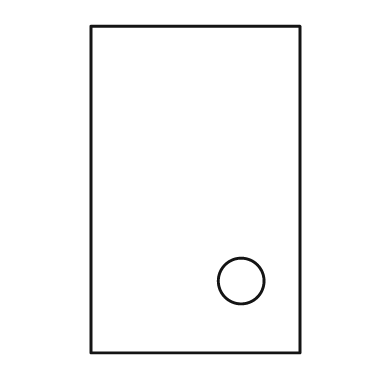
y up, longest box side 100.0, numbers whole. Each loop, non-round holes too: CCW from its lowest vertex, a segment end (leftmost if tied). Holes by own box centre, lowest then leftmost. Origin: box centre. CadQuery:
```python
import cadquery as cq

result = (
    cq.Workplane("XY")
    .moveTo(-32.0, -50.0)
    .lineTo(32.0, -50.0)
    .lineTo(32.0, 50.0)
    .lineTo(-32.0, 50.0)
    .close()
    .moveTo(14.0, -28.0)
    .circle(7.0)
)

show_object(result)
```